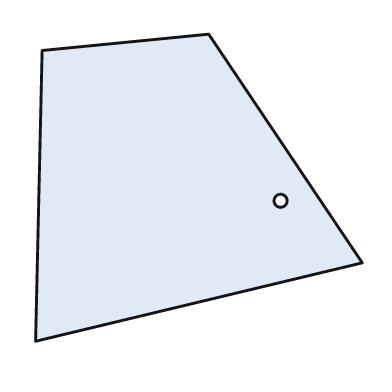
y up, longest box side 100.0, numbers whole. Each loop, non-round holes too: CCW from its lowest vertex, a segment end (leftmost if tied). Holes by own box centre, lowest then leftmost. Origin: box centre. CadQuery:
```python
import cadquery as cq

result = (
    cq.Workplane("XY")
    .moveTo(-50.0, -47.0)
    .lineTo(50.0, -23.0)
    .lineTo(3.0, 47.0)
    .lineTo(-48.0, 42.0)
    .close()
    .moveTo(25.0, -4.0)
    .circle(2.0)
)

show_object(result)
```